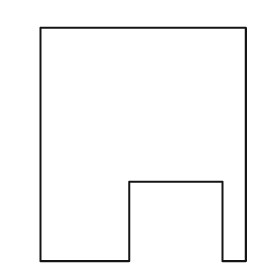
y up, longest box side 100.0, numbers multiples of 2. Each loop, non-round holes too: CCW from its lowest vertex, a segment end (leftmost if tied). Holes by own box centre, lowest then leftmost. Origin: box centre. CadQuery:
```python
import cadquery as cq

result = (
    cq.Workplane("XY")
    .moveTo(-44.0, -50.0)
    .lineTo(-6.0, -50.0)
    .lineTo(-6.0, -16.0)
    .lineTo(34.0, -16.0)
    .lineTo(34.0, -50.0)
    .lineTo(44.0, -50.0)
    .lineTo(44.0, 50.0)
    .lineTo(-44.0, 50.0)
    .close()
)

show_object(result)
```